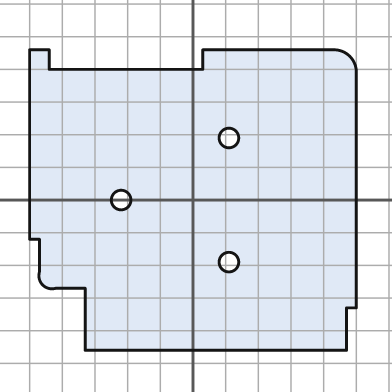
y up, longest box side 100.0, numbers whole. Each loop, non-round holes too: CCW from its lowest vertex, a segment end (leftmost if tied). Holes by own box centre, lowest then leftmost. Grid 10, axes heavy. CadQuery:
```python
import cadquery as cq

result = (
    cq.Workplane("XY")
    .moveTo(-33.0, -46.0)
    .lineTo(47.0, -46.0)
    .lineTo(47.0, -33.0)
    .lineTo(50.0, -33.0)
    .lineTo(50.0, 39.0)
    .threePointArc((48.0, 44.0), (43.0, 46.0))
    .lineTo(3.0, 46.0)
    .lineTo(3.0, 40.0)
    .lineTo(-44.0, 40.0)
    .lineTo(-44.0, 46.0)
    .lineTo(-50.0, 46.0)
    .lineTo(-50.0, -12.0)
    .lineTo(-47.0, -12.0)
    .lineTo(-47.0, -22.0)
    .threePointArc((-46.0, -26.0), (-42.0, -27.0))
    .lineTo(-33.0, -27.0)
    .close()
    .moveTo(11.0, -19.0)
    .circle(3.0)
    .moveTo(-22.0, 0.0)
    .circle(3.0)
    .moveTo(11.0, 19.0)
    .circle(3.0)
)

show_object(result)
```